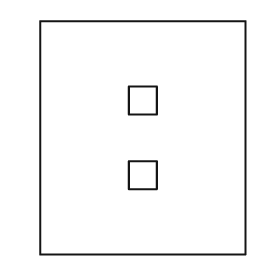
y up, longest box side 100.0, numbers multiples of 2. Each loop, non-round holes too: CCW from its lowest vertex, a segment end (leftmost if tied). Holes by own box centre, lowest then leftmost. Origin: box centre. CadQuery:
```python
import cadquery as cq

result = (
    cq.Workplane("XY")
    .moveTo(-44.0, -50.0)
    .lineTo(44.0, -50.0)
    .lineTo(44.0, 50.0)
    .lineTo(-44.0, 50.0)
    .close()
    .moveTo(-6.0, -22.0)
    .lineTo(6.0, -22.0)
    .lineTo(6.0, -10.0)
    .lineTo(-6.0, -10.0)
    .close()
    .moveTo(-6.0, 10.0)
    .lineTo(6.0, 10.0)
    .lineTo(6.0, 22.0)
    .lineTo(-6.0, 22.0)
    .close()
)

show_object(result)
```